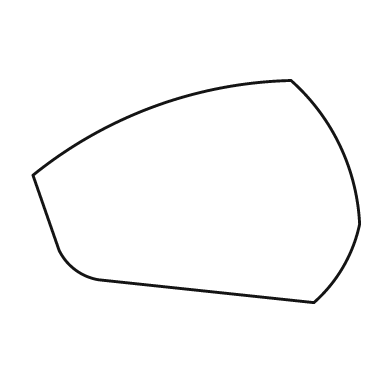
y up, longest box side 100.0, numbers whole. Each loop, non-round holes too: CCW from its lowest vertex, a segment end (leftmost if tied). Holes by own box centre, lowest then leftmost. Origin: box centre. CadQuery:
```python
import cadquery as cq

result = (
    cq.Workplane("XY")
    .moveTo(36.0, -34.0)
    .threePointArc((45.0, -23.0), (50.0, -10.0))
    .threePointArc((44.0, 14.0), (29.0, 34.0))
    .threePointArc((-13.0, 26.0), (-50.0, 5.0))
    .lineTo(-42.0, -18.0)
    .threePointArc((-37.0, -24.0), (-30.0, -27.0))
    .close()
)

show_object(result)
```